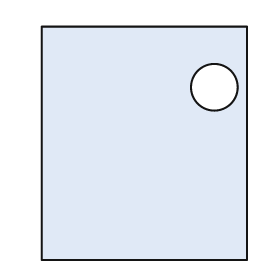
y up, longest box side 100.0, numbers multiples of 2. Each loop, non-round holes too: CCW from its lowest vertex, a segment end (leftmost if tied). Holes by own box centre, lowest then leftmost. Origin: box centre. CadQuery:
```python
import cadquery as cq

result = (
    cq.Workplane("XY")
    .moveTo(-44.0, -50.0)
    .lineTo(44.0, -50.0)
    .lineTo(44.0, 50.0)
    .lineTo(-44.0, 50.0)
    .close()
    .moveTo(30.0, 24.0)
    .circle(10.0)
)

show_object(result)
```